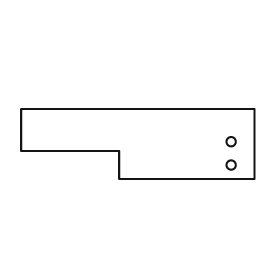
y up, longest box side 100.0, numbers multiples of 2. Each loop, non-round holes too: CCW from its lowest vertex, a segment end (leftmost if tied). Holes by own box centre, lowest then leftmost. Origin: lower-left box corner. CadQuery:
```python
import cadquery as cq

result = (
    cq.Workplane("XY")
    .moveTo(42.0, 0.0)
    .lineTo(100.0, 0.0)
    .lineTo(100.0, 30.0)
    .lineTo(0.0, 30.0)
    .lineTo(0.0, 12.0)
    .lineTo(42.0, 12.0)
    .close()
    .moveTo(90.0, 6.0)
    .circle(2.0)
    .moveTo(90.0, 16.0)
    .circle(2.0)
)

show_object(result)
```